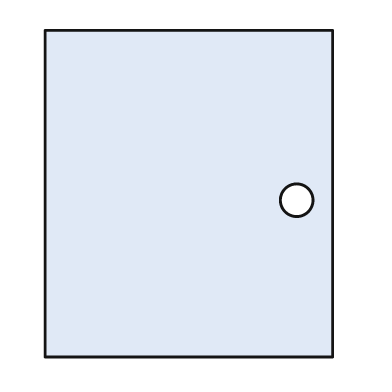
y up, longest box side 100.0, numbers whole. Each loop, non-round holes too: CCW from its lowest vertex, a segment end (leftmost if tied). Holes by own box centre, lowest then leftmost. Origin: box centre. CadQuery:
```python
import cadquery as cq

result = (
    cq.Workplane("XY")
    .moveTo(-44.0, -50.0)
    .lineTo(44.0, -50.0)
    .lineTo(44.0, 50.0)
    .lineTo(-44.0, 50.0)
    .close()
    .moveTo(33.0, -2.0)
    .circle(5.0)
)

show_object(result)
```